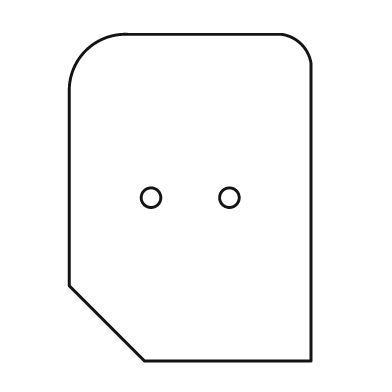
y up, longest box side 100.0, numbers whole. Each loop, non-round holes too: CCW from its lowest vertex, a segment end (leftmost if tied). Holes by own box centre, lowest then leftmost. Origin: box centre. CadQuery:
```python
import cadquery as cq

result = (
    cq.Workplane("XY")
    .moveTo(-14.0, -50.0)
    .lineTo(37.0, -50.0)
    .lineTo(37.0, 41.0)
    .threePointArc((34.0, 47.0), (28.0, 50.0))
    .lineTo(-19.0, 50.0)
    .threePointArc((-32.0, 45.0), (-37.0, 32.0))
    .lineTo(-37.0, -27.0)
    .close()
    .moveTo(-12.0, 0.0)
    .circle(3.0)
    .moveTo(12.0, 0.0)
    .circle(3.0)
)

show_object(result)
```